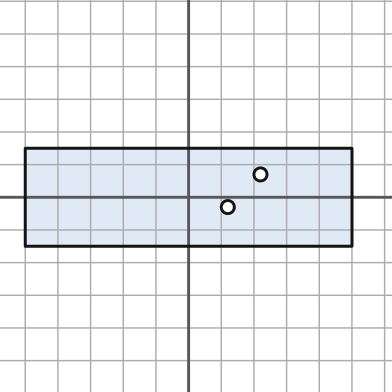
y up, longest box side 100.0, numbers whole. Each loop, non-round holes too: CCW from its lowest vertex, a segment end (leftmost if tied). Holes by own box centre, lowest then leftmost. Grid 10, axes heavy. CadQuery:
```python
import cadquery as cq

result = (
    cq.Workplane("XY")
    .moveTo(-50.0, -15.0)
    .lineTo(50.0, -15.0)
    .lineTo(50.0, 15.0)
    .lineTo(-50.0, 15.0)
    .close()
    .moveTo(12.0, -3.0)
    .circle(2.0)
    .moveTo(22.0, 7.0)
    .circle(2.0)
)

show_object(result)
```